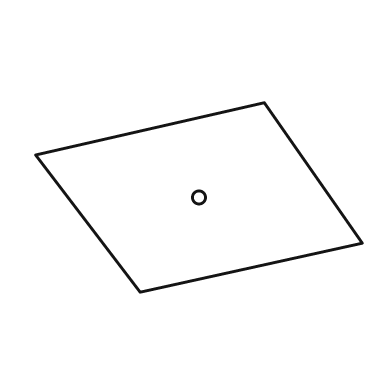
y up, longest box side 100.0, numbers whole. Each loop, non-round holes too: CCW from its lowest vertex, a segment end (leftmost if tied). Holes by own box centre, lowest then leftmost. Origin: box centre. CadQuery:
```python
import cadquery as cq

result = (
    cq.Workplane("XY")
    .moveTo(-18.0, -29.0)
    .lineTo(50.0, -14.0)
    .lineTo(20.0, 29.0)
    .lineTo(-50.0, 13.0)
    .close()
    .moveTo(0.0, 0.0)
    .circle(2.0)
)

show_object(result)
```